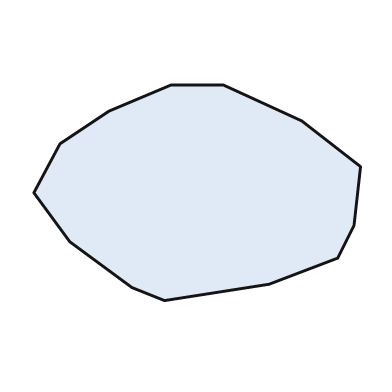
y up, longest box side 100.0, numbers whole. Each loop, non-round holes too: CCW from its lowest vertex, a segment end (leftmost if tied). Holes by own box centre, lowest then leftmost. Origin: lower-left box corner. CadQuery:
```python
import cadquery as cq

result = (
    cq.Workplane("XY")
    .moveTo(40.0, 0.0)
    .lineTo(72.0, 5.0)
    .lineTo(93.0, 13.0)
    .lineTo(98.0, 23.0)
    .lineTo(100.0, 41.0)
    .lineTo(82.0, 55.0)
    .lineTo(58.0, 66.0)
    .lineTo(42.0, 66.0)
    .lineTo(23.0, 58.0)
    .lineTo(8.0, 48.0)
    .lineTo(0.0, 33.0)
    .lineTo(11.0, 18.0)
    .lineTo(30.0, 4.0)
    .close()
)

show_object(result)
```